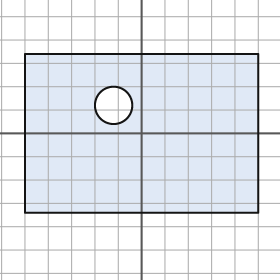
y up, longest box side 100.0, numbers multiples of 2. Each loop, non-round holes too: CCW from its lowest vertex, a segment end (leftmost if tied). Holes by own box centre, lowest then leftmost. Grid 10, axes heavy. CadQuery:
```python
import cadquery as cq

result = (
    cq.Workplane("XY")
    .moveTo(-50.0, -34.0)
    .lineTo(50.0, -34.0)
    .lineTo(50.0, 34.0)
    .lineTo(-50.0, 34.0)
    .close()
    .moveTo(-12.0, 12.0)
    .circle(8.0)
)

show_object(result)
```